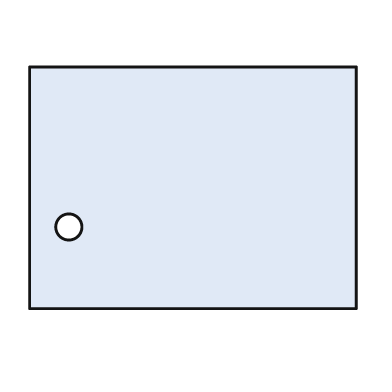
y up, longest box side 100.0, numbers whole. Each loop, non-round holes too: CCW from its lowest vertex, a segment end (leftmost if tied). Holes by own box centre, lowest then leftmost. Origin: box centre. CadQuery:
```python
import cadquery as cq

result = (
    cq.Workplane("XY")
    .moveTo(-50.0, -37.0)
    .lineTo(50.0, -37.0)
    .lineTo(50.0, 37.0)
    .lineTo(-50.0, 37.0)
    .close()
    .moveTo(-38.0, -12.0)
    .circle(4.0)
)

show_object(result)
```